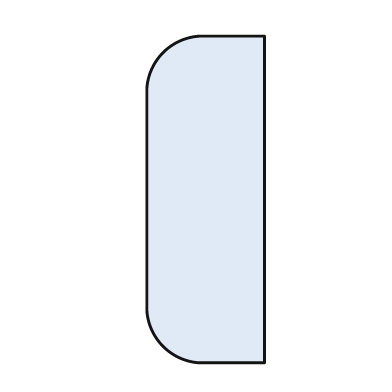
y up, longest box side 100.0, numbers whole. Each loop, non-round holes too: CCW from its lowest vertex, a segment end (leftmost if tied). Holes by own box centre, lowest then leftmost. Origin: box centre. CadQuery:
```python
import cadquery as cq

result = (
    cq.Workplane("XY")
    .moveTo(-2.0, -50.0)
    .lineTo(18.0, -50.0)
    .lineTo(18.0, 50.0)
    .lineTo(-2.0, 50.0)
    .threePointArc((-13.0, 45.0), (-18.0, 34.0))
    .lineTo(-18.0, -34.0)
    .threePointArc((-13.0, -45.0), (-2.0, -50.0))
    .close()
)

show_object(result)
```